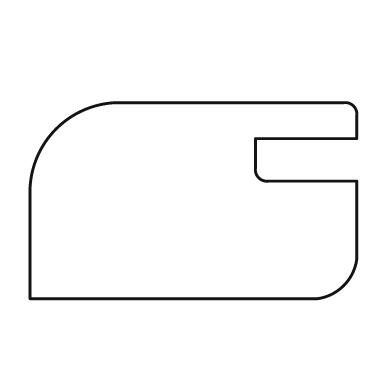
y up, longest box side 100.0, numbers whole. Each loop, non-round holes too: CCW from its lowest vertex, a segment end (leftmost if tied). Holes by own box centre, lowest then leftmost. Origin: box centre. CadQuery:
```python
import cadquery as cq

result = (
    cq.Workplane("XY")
    .moveTo(-50.0, -30.0)
    .lineTo(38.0, -30.0)
    .threePointArc((46.0, -26.0), (50.0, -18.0))
    .lineTo(50.0, 6.0)
    .lineTo(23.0, 6.0)
    .threePointArc((20.0, 7.0), (19.0, 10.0))
    .lineTo(19.0, 19.0)
    .lineTo(50.0, 19.0)
    .lineTo(50.0, 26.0)
    .threePointArc((49.0, 29.0), (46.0, 30.0))
    .lineTo(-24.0, 30.0)
    .threePointArc((-42.0, 22.0), (-50.0, 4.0))
    .close()
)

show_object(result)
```